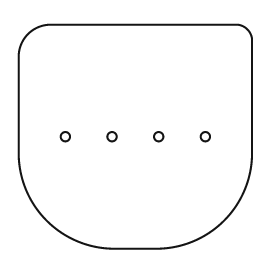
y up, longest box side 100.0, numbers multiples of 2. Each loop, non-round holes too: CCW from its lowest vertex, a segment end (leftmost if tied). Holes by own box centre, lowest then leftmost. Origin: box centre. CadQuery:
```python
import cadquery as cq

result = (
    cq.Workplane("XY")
    .moveTo(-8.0, -48.0)
    .lineTo(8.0, -48.0)
    .threePointArc((38.0, -36.0), (50.0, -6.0))
    .lineTo(50.0, 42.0)
    .threePointArc((48.0, 46.0), (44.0, 48.0))
    .lineTo(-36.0, 48.0)
    .threePointArc((-46.0, 44.0), (-50.0, 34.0))
    .lineTo(-50.0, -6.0)
    .threePointArc((-38.0, -36.0), (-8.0, -48.0))
    .close()
    .moveTo(-30.0, 0.0)
    .circle(2.0)
    .moveTo(-10.0, 0.0)
    .circle(2.0)
    .moveTo(10.0, 0.0)
    .circle(2.0)
    .moveTo(30.0, 0.0)
    .circle(2.0)
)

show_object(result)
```